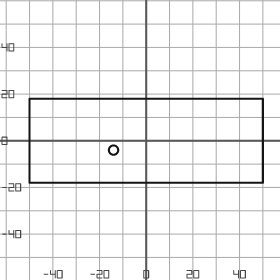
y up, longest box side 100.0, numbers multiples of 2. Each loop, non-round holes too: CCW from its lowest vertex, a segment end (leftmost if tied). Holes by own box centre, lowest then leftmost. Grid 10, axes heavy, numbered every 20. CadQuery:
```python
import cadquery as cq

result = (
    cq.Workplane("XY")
    .moveTo(-50.0, -18.0)
    .lineTo(50.0, -18.0)
    .lineTo(50.0, 18.0)
    .lineTo(-50.0, 18.0)
    .close()
    .moveTo(-14.0, -4.0)
    .circle(2.0)
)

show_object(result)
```